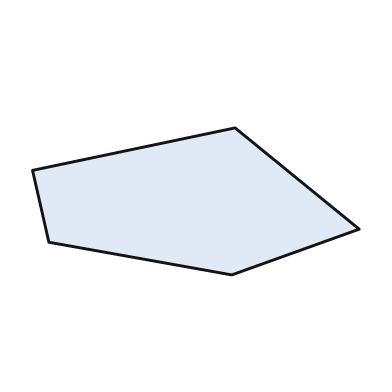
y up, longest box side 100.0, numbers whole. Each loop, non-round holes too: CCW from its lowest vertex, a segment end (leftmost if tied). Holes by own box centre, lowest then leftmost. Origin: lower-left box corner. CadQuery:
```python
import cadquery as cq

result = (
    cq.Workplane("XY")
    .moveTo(61.0, 0.0)
    .lineTo(100.0, 14.0)
    .lineTo(62.0, 45.0)
    .lineTo(0.0, 32.0)
    .lineTo(5.0, 10.0)
    .close()
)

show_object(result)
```